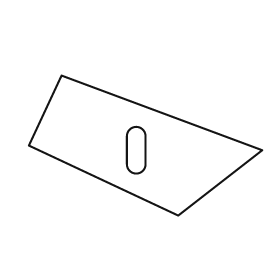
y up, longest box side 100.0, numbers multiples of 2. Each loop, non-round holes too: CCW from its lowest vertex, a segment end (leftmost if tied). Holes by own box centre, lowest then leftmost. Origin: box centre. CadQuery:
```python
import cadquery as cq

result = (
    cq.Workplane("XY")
    .moveTo(14.0, -30.0)
    .lineTo(50.0, -2.0)
    .lineTo(-36.0, 30.0)
    .lineTo(-50.0, 0.0)
    .close()
    .moveTo(-8.0, -8.0)
    .threePointArc((-4.0, -12.0), (0.0, -8.0))
    .lineTo(0.0, 4.0)
    .threePointArc((-4.0, 8.0), (-8.0, 4.0))
    .close()
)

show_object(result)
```